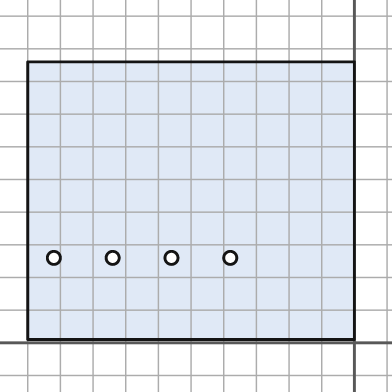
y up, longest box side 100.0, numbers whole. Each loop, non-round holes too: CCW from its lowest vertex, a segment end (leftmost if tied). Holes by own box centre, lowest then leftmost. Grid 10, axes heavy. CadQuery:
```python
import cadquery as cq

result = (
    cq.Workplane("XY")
    .moveTo(-100.0, 1.0)
    .lineTo(0.0, 1.0)
    .lineTo(0.0, 86.0)
    .lineTo(-100.0, 86.0)
    .close()
    .moveTo(-92.0, 26.0)
    .circle(2.0)
    .moveTo(-74.0, 26.0)
    .circle(2.0)
    .moveTo(-56.0, 26.0)
    .circle(2.0)
    .moveTo(-38.0, 26.0)
    .circle(2.0)
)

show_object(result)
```